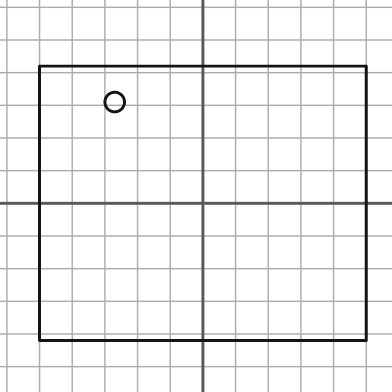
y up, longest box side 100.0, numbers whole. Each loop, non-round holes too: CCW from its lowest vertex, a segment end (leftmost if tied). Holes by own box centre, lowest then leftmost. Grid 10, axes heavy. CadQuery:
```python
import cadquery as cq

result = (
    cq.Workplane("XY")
    .moveTo(-50.0, -42.0)
    .lineTo(50.0, -42.0)
    .lineTo(50.0, 42.0)
    .lineTo(-50.0, 42.0)
    .close()
    .moveTo(-27.0, 31.0)
    .circle(3.0)
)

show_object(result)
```